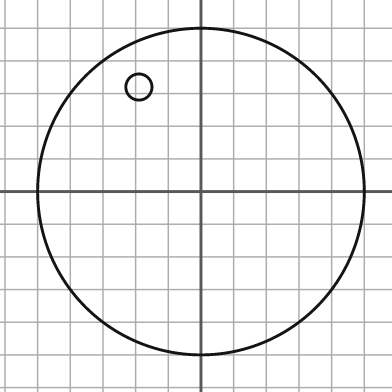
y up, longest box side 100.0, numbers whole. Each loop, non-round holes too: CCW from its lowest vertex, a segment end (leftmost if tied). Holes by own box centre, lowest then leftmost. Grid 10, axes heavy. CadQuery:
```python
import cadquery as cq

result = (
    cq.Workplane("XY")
    .moveTo(0.0, 0.0)
    .circle(50.0)
    .moveTo(-19.0, 32.0)
    .circle(4.0)
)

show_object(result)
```